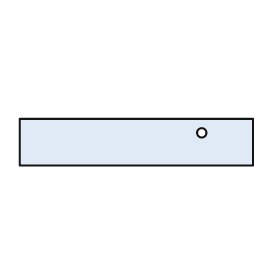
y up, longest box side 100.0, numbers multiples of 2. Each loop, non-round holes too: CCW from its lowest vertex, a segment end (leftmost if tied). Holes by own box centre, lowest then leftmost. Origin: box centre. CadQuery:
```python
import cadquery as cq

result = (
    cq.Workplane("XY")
    .moveTo(-50.0, -10.0)
    .lineTo(50.0, -10.0)
    .lineTo(50.0, 10.0)
    .lineTo(-50.0, 10.0)
    .close()
    .moveTo(28.0, 4.0)
    .circle(2.0)
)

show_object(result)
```